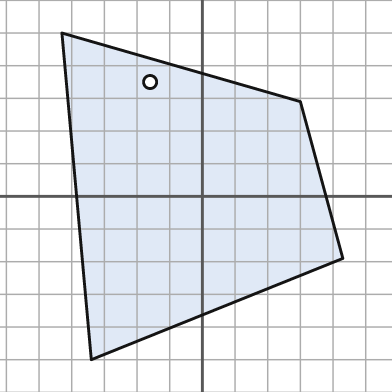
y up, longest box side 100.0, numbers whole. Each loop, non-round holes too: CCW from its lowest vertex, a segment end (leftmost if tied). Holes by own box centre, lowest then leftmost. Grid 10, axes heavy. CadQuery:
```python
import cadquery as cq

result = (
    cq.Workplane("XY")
    .moveTo(-34.0, -50.0)
    .lineTo(43.0, -19.0)
    .lineTo(30.0, 29.0)
    .lineTo(-43.0, 50.0)
    .close()
    .moveTo(-16.0, 35.0)
    .circle(2.0)
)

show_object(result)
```